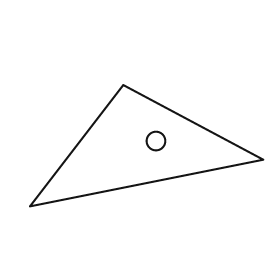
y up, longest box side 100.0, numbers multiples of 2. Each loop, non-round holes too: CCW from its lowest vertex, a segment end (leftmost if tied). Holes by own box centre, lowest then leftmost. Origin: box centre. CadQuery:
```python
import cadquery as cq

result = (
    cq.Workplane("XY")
    .moveTo(-50.0, -26.0)
    .lineTo(50.0, -6.0)
    .lineTo(-10.0, 26.0)
    .close()
    .moveTo(4.0, 2.0)
    .circle(4.0)
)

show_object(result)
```